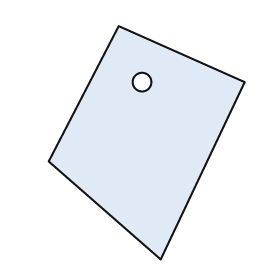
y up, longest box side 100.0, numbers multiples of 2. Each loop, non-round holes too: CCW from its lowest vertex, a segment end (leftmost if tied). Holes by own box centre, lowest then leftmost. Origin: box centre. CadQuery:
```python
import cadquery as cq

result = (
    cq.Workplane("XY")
    .moveTo(6.0, -50.0)
    .lineTo(42.0, 26.0)
    .lineTo(-12.0, 50.0)
    .lineTo(-42.0, -8.0)
    .close()
    .moveTo(-2.0, 26.0)
    .circle(4.0)
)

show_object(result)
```